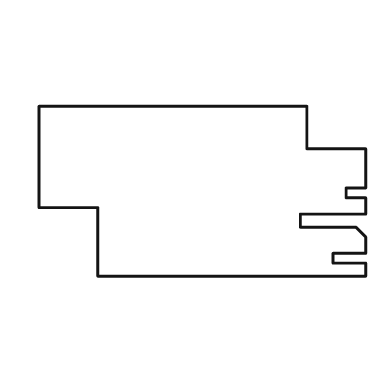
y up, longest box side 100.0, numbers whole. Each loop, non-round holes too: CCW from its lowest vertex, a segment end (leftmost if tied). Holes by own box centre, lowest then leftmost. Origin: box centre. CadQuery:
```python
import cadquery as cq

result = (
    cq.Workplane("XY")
    .moveTo(-32.0, -26.0)
    .lineTo(50.0, -26.0)
    .lineTo(50.0, -22.0)
    .lineTo(40.0, -22.0)
    .lineTo(40.0, -19.0)
    .lineTo(50.0, -19.0)
    .lineTo(50.0, -14.0)
    .lineTo(47.0, -11.0)
    .lineTo(30.0, -11.0)
    .lineTo(30.0, -7.0)
    .lineTo(50.0, -7.0)
    .lineTo(50.0, -2.0)
    .lineTo(44.0, -2.0)
    .lineTo(44.0, 1.0)
    .lineTo(50.0, 1.0)
    .lineTo(50.0, 13.0)
    .lineTo(32.0, 13.0)
    .lineTo(32.0, 26.0)
    .lineTo(-50.0, 26.0)
    .lineTo(-50.0, -5.0)
    .lineTo(-32.0, -5.0)
    .close()
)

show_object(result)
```